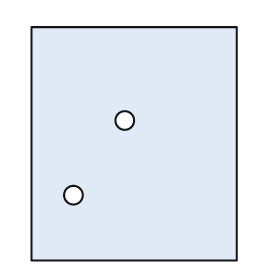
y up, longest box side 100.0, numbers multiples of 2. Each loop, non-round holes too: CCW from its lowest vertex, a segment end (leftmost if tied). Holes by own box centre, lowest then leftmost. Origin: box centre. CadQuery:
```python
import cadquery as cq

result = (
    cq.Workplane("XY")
    .moveTo(-44.0, -50.0)
    .lineTo(44.0, -50.0)
    .lineTo(44.0, 50.0)
    .lineTo(-44.0, 50.0)
    .close()
    .moveTo(-26.0, -22.0)
    .circle(4.0)
    .moveTo(-4.0, 10.0)
    .circle(4.0)
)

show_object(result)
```